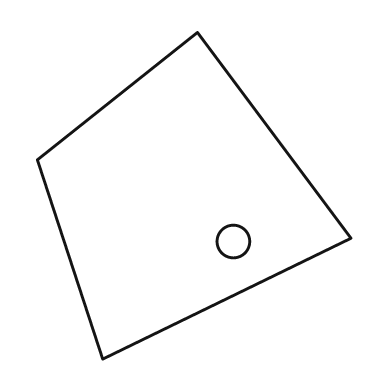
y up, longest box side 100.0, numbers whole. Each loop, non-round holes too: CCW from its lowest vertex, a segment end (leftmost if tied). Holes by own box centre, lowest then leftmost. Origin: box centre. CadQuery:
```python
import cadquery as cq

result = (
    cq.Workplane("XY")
    .moveTo(-28.0, -50.0)
    .lineTo(48.0, -13.0)
    .lineTo(1.0, 50.0)
    .lineTo(-48.0, 11.0)
    .close()
    .moveTo(12.0, -14.0)
    .circle(5.0)
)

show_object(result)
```